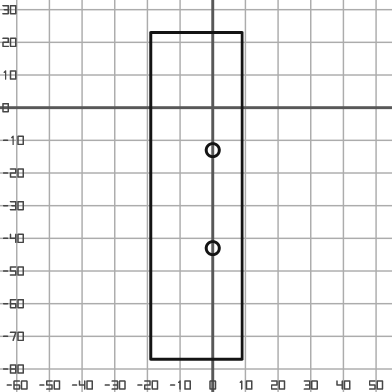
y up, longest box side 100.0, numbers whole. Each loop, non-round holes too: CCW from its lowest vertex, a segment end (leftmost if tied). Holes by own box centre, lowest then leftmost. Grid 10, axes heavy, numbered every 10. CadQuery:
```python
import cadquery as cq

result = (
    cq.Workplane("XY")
    .moveTo(-19.0, -77.0)
    .lineTo(9.0, -77.0)
    .lineTo(9.0, 23.0)
    .lineTo(-19.0, 23.0)
    .close()
    .moveTo(0.0, -43.0)
    .circle(2.0)
    .moveTo(0.0, -13.0)
    .circle(2.0)
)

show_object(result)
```